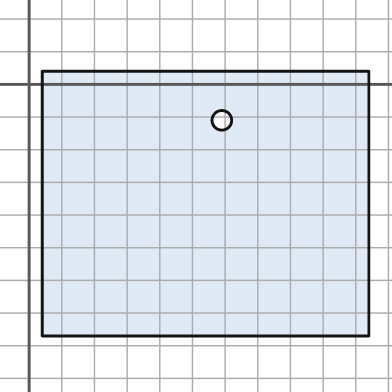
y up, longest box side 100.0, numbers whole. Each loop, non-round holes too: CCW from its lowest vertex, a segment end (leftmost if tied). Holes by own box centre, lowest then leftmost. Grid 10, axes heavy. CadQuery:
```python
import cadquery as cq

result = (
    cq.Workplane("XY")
    .moveTo(4.0, -77.0)
    .lineTo(104.0, -77.0)
    .lineTo(104.0, 4.0)
    .lineTo(4.0, 4.0)
    .close()
    .moveTo(59.0, -11.0)
    .circle(3.0)
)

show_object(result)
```